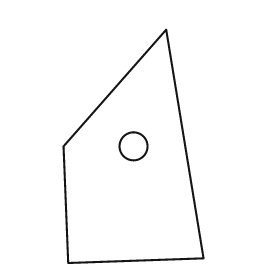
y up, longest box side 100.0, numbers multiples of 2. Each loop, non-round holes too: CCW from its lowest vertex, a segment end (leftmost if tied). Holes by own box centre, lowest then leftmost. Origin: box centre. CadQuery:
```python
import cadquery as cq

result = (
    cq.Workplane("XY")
    .moveTo(-28.0, -50.0)
    .lineTo(30.0, -48.0)
    .lineTo(14.0, 50.0)
    .lineTo(-30.0, 0.0)
    .close()
    .moveTo(0.0, 0.0)
    .circle(6.0)
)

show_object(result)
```